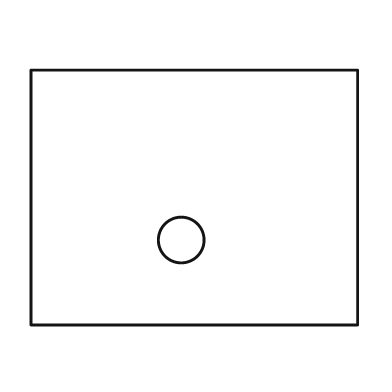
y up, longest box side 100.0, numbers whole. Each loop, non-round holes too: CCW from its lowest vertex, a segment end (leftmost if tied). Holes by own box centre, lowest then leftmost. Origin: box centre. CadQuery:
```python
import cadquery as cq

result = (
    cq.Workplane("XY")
    .moveTo(-50.0, -39.0)
    .lineTo(50.0, -39.0)
    .lineTo(50.0, 39.0)
    .lineTo(-50.0, 39.0)
    .close()
    .moveTo(-4.0, -13.0)
    .circle(7.0)
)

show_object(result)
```